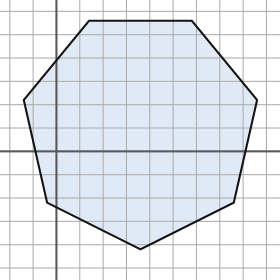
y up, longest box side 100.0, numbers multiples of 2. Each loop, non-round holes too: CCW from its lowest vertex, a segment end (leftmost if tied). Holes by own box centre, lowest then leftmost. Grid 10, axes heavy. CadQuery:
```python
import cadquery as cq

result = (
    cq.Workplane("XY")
    .moveTo(36.0, -42.0)
    .lineTo(76.0, -22.0)
    .lineTo(86.0, 22.0)
    .lineTo(58.0, 56.0)
    .lineTo(14.0, 56.0)
    .lineTo(-14.0, 22.0)
    .lineTo(-4.0, -22.0)
    .close()
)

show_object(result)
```